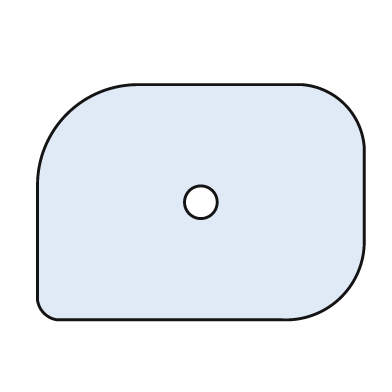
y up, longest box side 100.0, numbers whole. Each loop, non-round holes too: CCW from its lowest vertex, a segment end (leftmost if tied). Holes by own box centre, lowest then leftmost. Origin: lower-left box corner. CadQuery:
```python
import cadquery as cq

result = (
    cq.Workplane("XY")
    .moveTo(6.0, 0.0)
    .lineTo(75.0, 0.0)
    .threePointArc((93.0, 7.0), (100.0, 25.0))
    .lineTo(100.0, 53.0)
    .threePointArc((94.0, 66.0), (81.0, 72.0))
    .lineTo(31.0, 72.0)
    .threePointArc((9.0, 63.0), (0.0, 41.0))
    .lineTo(0.0, 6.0)
    .threePointArc((2.0, 2.0), (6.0, 0.0))
    .close()
    .moveTo(50.0, 36.0)
    .circle(5.0)
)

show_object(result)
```